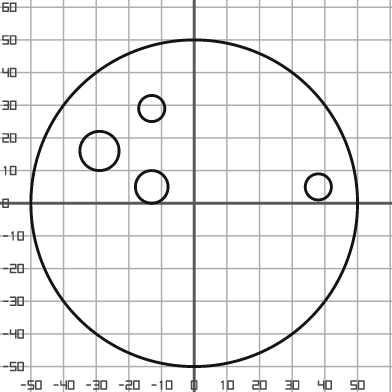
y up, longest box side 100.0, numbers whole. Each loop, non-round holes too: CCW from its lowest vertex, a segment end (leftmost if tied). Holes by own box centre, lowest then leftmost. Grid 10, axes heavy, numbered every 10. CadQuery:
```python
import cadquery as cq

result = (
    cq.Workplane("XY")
    .moveTo(0.0, 0.0)
    .circle(50.0)
    .moveTo(-13.0, 5.0)
    .circle(5.0)
    .moveTo(38.0, 5.0)
    .circle(4.0)
    .moveTo(-29.0, 16.0)
    .circle(6.0)
    .moveTo(-13.0, 29.0)
    .circle(4.0)
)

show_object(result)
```